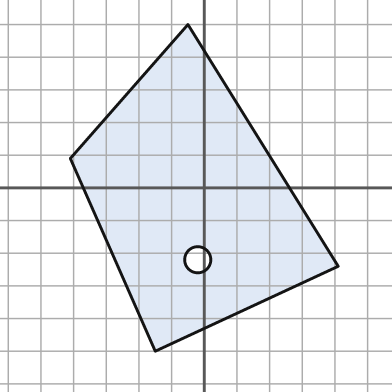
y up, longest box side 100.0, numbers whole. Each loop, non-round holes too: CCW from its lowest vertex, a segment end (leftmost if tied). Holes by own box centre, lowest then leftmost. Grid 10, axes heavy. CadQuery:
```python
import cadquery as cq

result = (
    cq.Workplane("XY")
    .moveTo(-15.0, -50.0)
    .lineTo(41.0, -24.0)
    .lineTo(-5.0, 50.0)
    .lineTo(-41.0, 9.0)
    .close()
    .moveTo(-2.0, -22.0)
    .circle(4.0)
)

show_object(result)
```